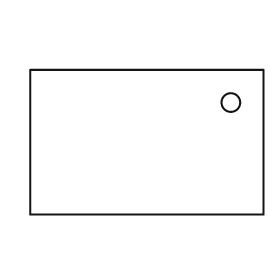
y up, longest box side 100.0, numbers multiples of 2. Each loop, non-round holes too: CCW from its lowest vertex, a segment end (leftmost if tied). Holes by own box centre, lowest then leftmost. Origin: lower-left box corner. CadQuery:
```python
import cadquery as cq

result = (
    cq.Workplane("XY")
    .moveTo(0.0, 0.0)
    .lineTo(100.0, 0.0)
    .lineTo(100.0, 62.0)
    .lineTo(0.0, 62.0)
    .close()
    .moveTo(86.0, 48.0)
    .circle(4.0)
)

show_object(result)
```